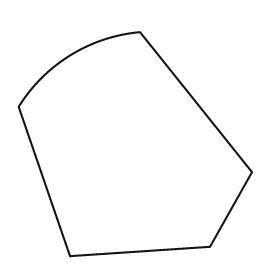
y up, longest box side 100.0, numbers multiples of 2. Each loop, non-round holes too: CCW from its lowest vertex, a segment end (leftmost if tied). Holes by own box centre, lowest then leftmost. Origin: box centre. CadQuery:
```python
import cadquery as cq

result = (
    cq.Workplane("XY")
    .moveTo(-28.0, -48.0)
    .lineTo(32.0, -44.0)
    .lineTo(50.0, -12.0)
    .lineTo(2.0, 48.0)
    .threePointArc((-28.0, 38.0), (-50.0, 16.0))
    .close()
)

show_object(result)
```